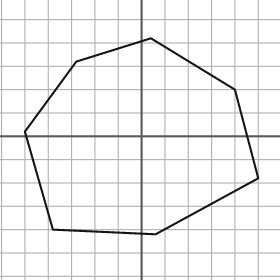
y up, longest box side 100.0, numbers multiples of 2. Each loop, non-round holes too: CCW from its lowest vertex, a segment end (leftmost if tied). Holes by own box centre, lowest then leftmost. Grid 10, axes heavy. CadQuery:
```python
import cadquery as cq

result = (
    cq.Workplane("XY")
    .moveTo(6.0, -42.0)
    .lineTo(50.0, -18.0)
    .lineTo(40.0, 20.0)
    .lineTo(4.0, 42.0)
    .lineTo(-28.0, 32.0)
    .lineTo(-50.0, 2.0)
    .lineTo(-38.0, -40.0)
    .close()
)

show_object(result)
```